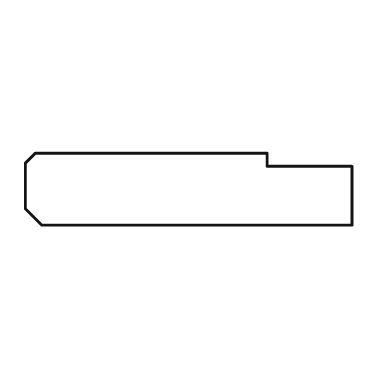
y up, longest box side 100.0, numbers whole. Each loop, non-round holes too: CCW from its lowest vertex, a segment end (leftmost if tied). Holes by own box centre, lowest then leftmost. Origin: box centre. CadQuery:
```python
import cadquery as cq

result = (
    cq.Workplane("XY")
    .moveTo(-45.0, -11.0)
    .lineTo(50.0, -11.0)
    .lineTo(50.0, 7.0)
    .lineTo(24.0, 7.0)
    .lineTo(24.0, 11.0)
    .lineTo(-47.0, 11.0)
    .lineTo(-50.0, 8.0)
    .lineTo(-50.0, -6.0)
    .close()
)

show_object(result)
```